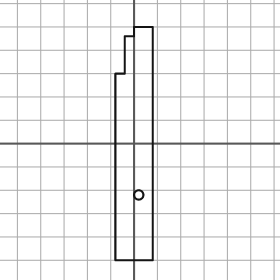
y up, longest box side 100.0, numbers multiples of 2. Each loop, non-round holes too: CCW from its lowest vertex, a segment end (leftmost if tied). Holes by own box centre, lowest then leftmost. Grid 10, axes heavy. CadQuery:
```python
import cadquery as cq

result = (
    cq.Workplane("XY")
    .moveTo(-8.0, -50.0)
    .lineTo(8.0, -50.0)
    .lineTo(8.0, 50.0)
    .lineTo(0.0, 50.0)
    .lineTo(0.0, 46.0)
    .lineTo(-4.0, 46.0)
    .lineTo(-4.0, 30.0)
    .lineTo(-8.0, 30.0)
    .close()
    .moveTo(2.0, -22.0)
    .circle(2.0)
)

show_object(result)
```